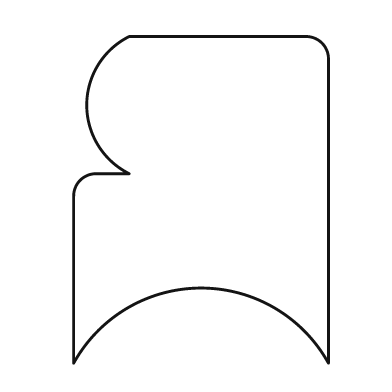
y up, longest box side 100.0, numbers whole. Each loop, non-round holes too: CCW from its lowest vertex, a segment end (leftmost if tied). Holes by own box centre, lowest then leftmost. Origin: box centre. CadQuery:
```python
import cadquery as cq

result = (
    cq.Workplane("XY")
    .moveTo(-39.0, -50.0)
    .threePointArc((0.0, -27.0), (39.0, -50.0))
    .lineTo(39.0, 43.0)
    .threePointArc((37.0, 48.0), (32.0, 50.0))
    .lineTo(-22.0, 50.0)
    .threePointArc((-35.0, 29.0), (-22.0, 8.0))
    .lineTo(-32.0, 8.0)
    .threePointArc((-37.0, 6.0), (-39.0, 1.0))
    .close()
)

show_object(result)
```